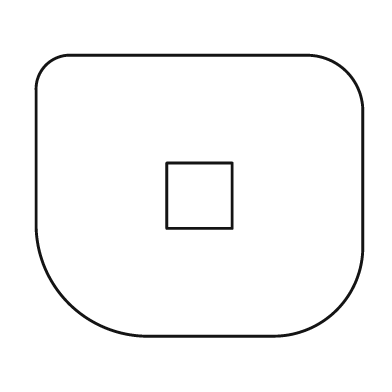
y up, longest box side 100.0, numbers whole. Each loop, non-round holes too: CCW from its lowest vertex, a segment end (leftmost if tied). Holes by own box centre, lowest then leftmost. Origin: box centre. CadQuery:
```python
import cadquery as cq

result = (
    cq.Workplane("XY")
    .moveTo(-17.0, -43.0)
    .lineTo(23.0, -43.0)
    .threePointArc((42.0, -35.0), (50.0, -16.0))
    .lineTo(50.0, 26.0)
    .threePointArc((45.0, 38.0), (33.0, 43.0))
    .lineTo(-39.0, 43.0)
    .threePointArc((-47.0, 40.0), (-50.0, 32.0))
    .lineTo(-50.0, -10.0)
    .threePointArc((-40.0, -33.0), (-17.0, -43.0))
    .close()
    .moveTo(-10.0, -10.0)
    .lineTo(10.0, -10.0)
    .lineTo(10.0, 10.0)
    .lineTo(-10.0, 10.0)
    .close()
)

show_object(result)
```